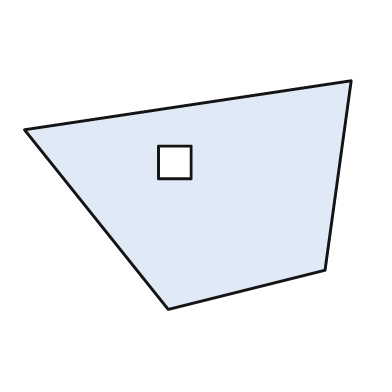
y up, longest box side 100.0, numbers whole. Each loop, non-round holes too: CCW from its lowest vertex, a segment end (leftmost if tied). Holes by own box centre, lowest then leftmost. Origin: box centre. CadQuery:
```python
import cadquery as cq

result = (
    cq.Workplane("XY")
    .moveTo(-6.0, -35.0)
    .lineTo(42.0, -23.0)
    .lineTo(50.0, 35.0)
    .lineTo(-50.0, 20.0)
    .close()
    .moveTo(-9.0, 5.0)
    .lineTo(1.0, 5.0)
    .lineTo(1.0, 15.0)
    .lineTo(-9.0, 15.0)
    .close()
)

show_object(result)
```